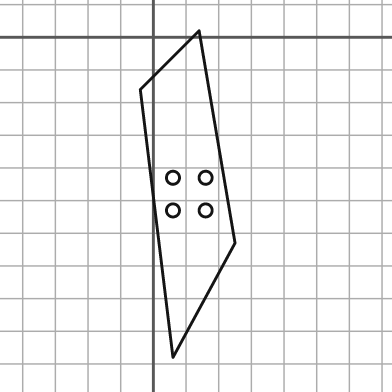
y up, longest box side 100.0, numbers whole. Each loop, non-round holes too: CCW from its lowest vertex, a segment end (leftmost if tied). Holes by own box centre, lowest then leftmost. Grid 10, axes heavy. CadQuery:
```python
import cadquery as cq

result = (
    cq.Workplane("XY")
    .moveTo(6.0, -98.0)
    .lineTo(25.0, -63.0)
    .lineTo(14.0, 2.0)
    .lineTo(-4.0, -16.0)
    .close()
    .moveTo(6.0, -53.0)
    .circle(2.0)
    .moveTo(16.0, -53.0)
    .circle(2.0)
    .moveTo(6.0, -43.0)
    .circle(2.0)
    .moveTo(16.0, -43.0)
    .circle(2.0)
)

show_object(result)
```